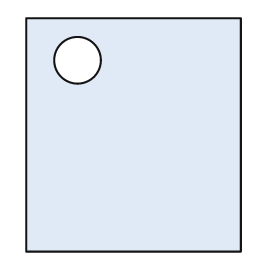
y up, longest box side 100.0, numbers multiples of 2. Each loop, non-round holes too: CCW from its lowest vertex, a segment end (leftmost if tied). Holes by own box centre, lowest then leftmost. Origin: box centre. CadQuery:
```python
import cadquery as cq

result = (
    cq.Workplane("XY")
    .moveTo(-46.0, -50.0)
    .lineTo(46.0, -50.0)
    .lineTo(46.0, 50.0)
    .lineTo(-46.0, 50.0)
    .close()
    .moveTo(-24.0, 32.0)
    .circle(10.0)
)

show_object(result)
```